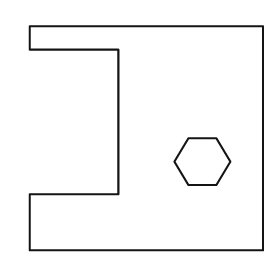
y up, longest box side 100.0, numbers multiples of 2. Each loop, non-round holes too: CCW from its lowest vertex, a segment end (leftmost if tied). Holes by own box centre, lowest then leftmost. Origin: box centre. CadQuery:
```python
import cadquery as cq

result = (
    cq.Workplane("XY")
    .moveTo(-50.0, -48.0)
    .lineTo(50.0, -48.0)
    .lineTo(50.0, 48.0)
    .lineTo(-50.0, 48.0)
    .lineTo(-50.0, 38.0)
    .lineTo(-12.0, 38.0)
    .lineTo(-12.0, -24.0)
    .lineTo(-50.0, -24.0)
    .close()
    .moveTo(18.0, -20.0)
    .lineTo(30.0, -20.0)
    .lineTo(36.0, -10.0)
    .lineTo(30.0, 0.0)
    .lineTo(18.0, 0.0)
    .lineTo(12.0, -10.0)
    .close()
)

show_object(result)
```